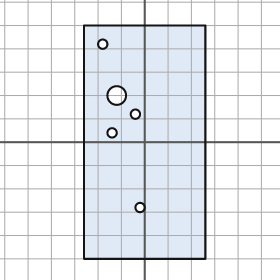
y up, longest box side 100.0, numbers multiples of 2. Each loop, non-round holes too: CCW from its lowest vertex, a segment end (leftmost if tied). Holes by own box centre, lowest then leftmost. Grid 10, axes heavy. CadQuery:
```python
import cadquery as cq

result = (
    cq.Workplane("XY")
    .moveTo(-26.0, -50.0)
    .lineTo(26.0, -50.0)
    .lineTo(26.0, 50.0)
    .lineTo(-26.0, 50.0)
    .close()
    .moveTo(-2.0, -28.0)
    .circle(2.0)
    .moveTo(-14.0, 4.0)
    .circle(2.0)
    .moveTo(-4.0, 12.0)
    .circle(2.0)
    .moveTo(-12.0, 20.0)
    .circle(4.0)
    .moveTo(-18.0, 42.0)
    .circle(2.0)
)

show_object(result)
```